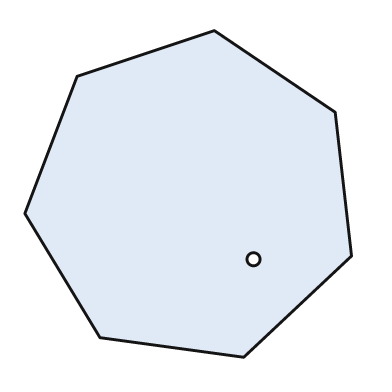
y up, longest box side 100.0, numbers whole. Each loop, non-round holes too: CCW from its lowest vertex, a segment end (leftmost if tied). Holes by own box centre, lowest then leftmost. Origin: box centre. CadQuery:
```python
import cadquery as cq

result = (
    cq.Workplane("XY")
    .moveTo(17.0, -50.0)
    .lineTo(50.0, -19.0)
    .lineTo(45.0, 25.0)
    .lineTo(8.0, 50.0)
    .lineTo(-34.0, 36.0)
    .lineTo(-50.0, -6.0)
    .lineTo(-27.0, -44.0)
    .close()
    .moveTo(20.0, -20.0)
    .circle(2.0)
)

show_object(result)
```